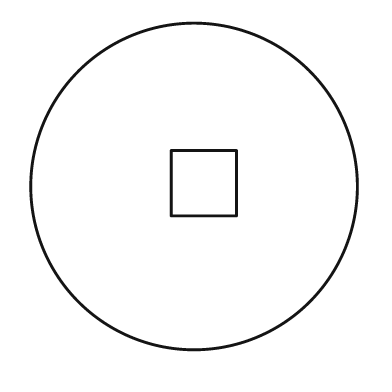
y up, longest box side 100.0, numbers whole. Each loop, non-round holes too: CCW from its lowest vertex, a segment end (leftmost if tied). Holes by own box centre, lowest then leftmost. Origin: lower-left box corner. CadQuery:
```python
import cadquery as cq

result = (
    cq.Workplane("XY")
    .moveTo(50.0, 50.0)
    .circle(50.0)
    .moveTo(43.0, 41.0)
    .lineTo(63.0, 41.0)
    .lineTo(63.0, 61.0)
    .lineTo(43.0, 61.0)
    .close()
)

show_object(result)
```